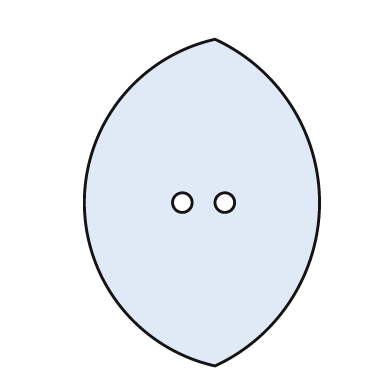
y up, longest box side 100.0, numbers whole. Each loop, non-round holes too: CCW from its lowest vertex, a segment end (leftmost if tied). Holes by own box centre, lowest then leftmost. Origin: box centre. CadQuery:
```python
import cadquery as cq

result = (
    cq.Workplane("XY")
    .moveTo(4.0, -50.0)
    .threePointArc((36.0, 0.0), (4.0, 50.0))
    .threePointArc((-36.0, 0.0), (4.0, -50.0))
    .close()
    .moveTo(-6.0, 0.0)
    .circle(3.0)
    .moveTo(7.0, 0.0)
    .circle(3.0)
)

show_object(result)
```